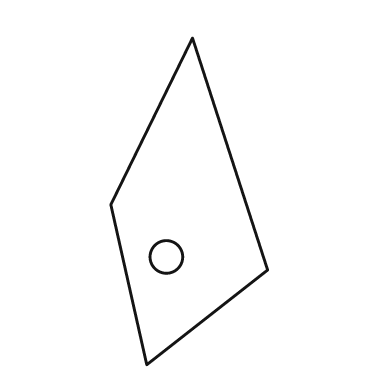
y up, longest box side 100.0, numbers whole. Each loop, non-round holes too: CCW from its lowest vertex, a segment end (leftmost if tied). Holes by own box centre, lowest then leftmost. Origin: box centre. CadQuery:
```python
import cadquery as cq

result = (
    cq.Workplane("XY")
    .moveTo(-13.0, -50.0)
    .lineTo(24.0, -21.0)
    .lineTo(1.0, 50.0)
    .lineTo(-24.0, -1.0)
    .close()
    .moveTo(-7.0, -17.0)
    .circle(5.0)
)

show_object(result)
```